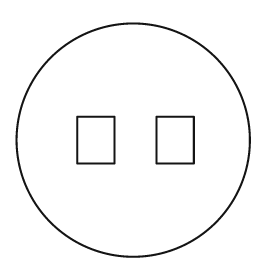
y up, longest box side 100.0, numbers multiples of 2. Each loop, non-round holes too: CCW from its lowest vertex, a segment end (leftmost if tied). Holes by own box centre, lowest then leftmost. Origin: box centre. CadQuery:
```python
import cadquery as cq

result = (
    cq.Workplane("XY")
    .moveTo(0.0, 0.0)
    .circle(50.0)
    .moveTo(-24.0, -10.0)
    .lineTo(-8.0, -10.0)
    .lineTo(-8.0, 10.0)
    .lineTo(-24.0, 10.0)
    .close()
    .moveTo(10.0, -10.0)
    .lineTo(26.0, -10.0)
    .lineTo(26.0, 10.0)
    .lineTo(10.0, 10.0)
    .close()
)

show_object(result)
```